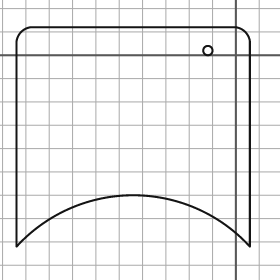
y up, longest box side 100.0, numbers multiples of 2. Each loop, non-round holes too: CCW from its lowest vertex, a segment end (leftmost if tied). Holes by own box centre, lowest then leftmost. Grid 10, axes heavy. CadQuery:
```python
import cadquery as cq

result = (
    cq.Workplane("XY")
    .moveTo(-94.0, -82.0)
    .threePointArc((-44.0, -60.0), (6.0, -82.0))
    .lineTo(6.0, 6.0)
    .threePointArc((4.0, 10.0), (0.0, 12.0))
    .lineTo(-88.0, 12.0)
    .threePointArc((-92.0, 10.0), (-94.0, 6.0))
    .close()
    .moveTo(-12.0, 2.0)
    .circle(2.0)
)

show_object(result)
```